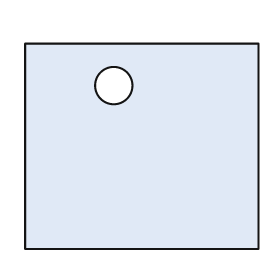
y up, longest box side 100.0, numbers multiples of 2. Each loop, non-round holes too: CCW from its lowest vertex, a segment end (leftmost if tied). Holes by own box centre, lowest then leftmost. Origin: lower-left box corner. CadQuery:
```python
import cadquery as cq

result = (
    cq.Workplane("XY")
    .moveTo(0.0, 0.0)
    .lineTo(100.0, 0.0)
    .lineTo(100.0, 88.0)
    .lineTo(0.0, 88.0)
    .close()
    .moveTo(38.0, 70.0)
    .circle(8.0)
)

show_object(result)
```